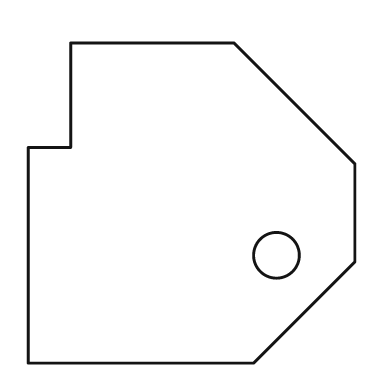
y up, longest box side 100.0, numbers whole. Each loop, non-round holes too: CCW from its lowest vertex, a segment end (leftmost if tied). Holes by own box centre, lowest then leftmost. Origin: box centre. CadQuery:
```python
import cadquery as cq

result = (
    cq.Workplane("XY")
    .moveTo(-50.0, -49.0)
    .lineTo(19.0, -49.0)
    .lineTo(50.0, -18.0)
    .lineTo(50.0, 12.0)
    .lineTo(13.0, 49.0)
    .lineTo(-37.0, 49.0)
    .lineTo(-37.0, 17.0)
    .lineTo(-50.0, 17.0)
    .close()
    .moveTo(26.0, -16.0)
    .circle(7.0)
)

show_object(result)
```